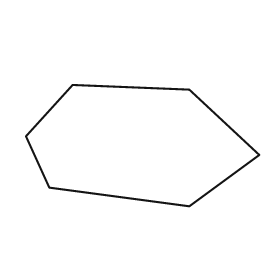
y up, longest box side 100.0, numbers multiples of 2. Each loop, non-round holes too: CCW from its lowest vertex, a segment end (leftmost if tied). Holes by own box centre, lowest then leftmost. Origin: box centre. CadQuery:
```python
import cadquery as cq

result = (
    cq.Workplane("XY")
    .moveTo(20.0, -26.0)
    .lineTo(50.0, -4.0)
    .lineTo(20.0, 24.0)
    .lineTo(-30.0, 26.0)
    .lineTo(-50.0, 4.0)
    .lineTo(-40.0, -18.0)
    .close()
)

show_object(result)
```